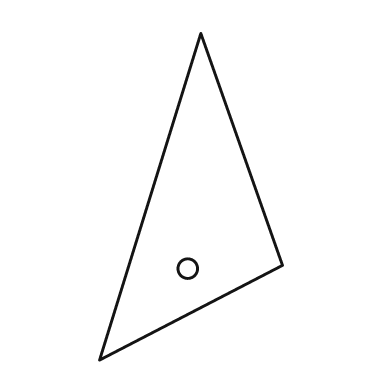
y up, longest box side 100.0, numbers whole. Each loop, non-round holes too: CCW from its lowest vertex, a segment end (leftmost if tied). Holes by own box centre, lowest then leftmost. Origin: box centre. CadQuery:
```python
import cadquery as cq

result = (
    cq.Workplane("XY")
    .moveTo(-28.0, -50.0)
    .lineTo(28.0, -21.0)
    .lineTo(3.0, 50.0)
    .close()
    .moveTo(-1.0, -22.0)
    .circle(3.0)
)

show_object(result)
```